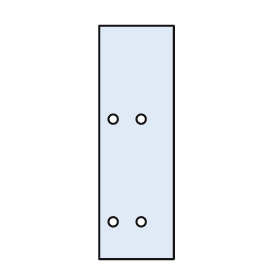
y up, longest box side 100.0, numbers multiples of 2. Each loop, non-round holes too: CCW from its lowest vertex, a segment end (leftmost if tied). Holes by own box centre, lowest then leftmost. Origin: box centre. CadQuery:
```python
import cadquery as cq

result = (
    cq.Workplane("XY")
    .moveTo(-16.0, -50.0)
    .lineTo(16.0, -50.0)
    .lineTo(16.0, 50.0)
    .lineTo(-16.0, 50.0)
    .close()
    .moveTo(-10.0, -34.0)
    .circle(2.0)
    .moveTo(2.0, -34.0)
    .circle(2.0)
    .moveTo(-10.0, 10.0)
    .circle(2.0)
    .moveTo(2.0, 10.0)
    .circle(2.0)
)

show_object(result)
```